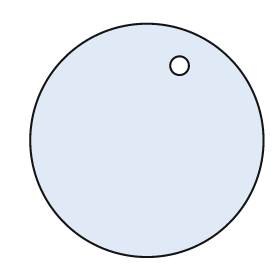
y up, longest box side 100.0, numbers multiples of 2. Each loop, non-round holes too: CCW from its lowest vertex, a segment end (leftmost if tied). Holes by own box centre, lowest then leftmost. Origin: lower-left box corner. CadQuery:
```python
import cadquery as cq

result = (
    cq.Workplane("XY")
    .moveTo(50.0, 50.0)
    .circle(50.0)
    .moveTo(64.0, 82.0)
    .circle(4.0)
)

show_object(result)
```